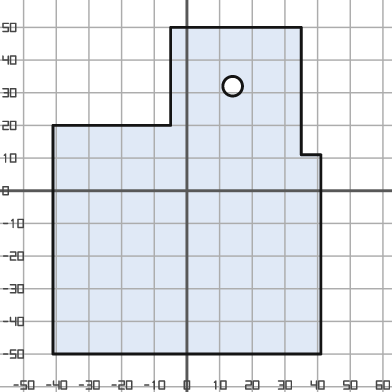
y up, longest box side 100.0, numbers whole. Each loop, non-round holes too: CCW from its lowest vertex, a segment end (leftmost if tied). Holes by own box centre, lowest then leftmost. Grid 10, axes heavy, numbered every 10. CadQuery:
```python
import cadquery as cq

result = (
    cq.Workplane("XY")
    .moveTo(-41.0, -50.0)
    .lineTo(41.0, -50.0)
    .lineTo(41.0, 11.0)
    .lineTo(35.0, 11.0)
    .lineTo(35.0, 50.0)
    .lineTo(-5.0, 50.0)
    .lineTo(-5.0, 20.0)
    .lineTo(-41.0, 20.0)
    .close()
    .moveTo(14.0, 32.0)
    .circle(3.0)
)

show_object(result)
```